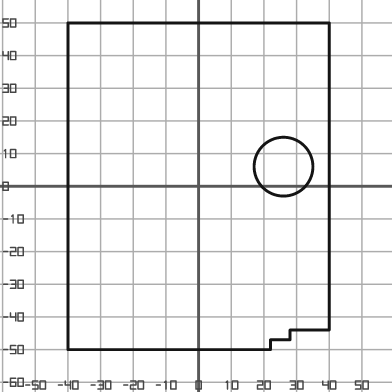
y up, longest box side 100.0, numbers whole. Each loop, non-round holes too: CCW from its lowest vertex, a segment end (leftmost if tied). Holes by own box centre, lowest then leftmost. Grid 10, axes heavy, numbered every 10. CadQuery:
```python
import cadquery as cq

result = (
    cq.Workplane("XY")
    .moveTo(-40.0, -50.0)
    .lineTo(22.0, -50.0)
    .lineTo(22.0, -47.0)
    .lineTo(28.0, -47.0)
    .lineTo(28.0, -44.0)
    .lineTo(40.0, -44.0)
    .lineTo(40.0, 50.0)
    .lineTo(-40.0, 50.0)
    .close()
    .moveTo(26.0, 6.0)
    .circle(9.0)
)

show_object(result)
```